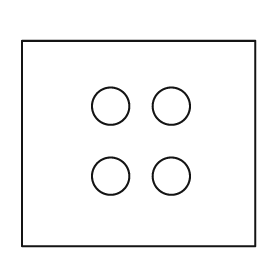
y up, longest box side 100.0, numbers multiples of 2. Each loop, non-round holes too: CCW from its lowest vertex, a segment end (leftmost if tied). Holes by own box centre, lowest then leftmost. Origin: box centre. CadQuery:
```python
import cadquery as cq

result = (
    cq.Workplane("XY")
    .moveTo(-50.0, -44.0)
    .lineTo(50.0, -44.0)
    .lineTo(50.0, 44.0)
    .lineTo(-50.0, 44.0)
    .close()
    .moveTo(-12.0, -14.0)
    .circle(8.0)
    .moveTo(14.0, -14.0)
    .circle(8.0)
    .moveTo(-12.0, 16.0)
    .circle(8.0)
    .moveTo(14.0, 16.0)
    .circle(8.0)
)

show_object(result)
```